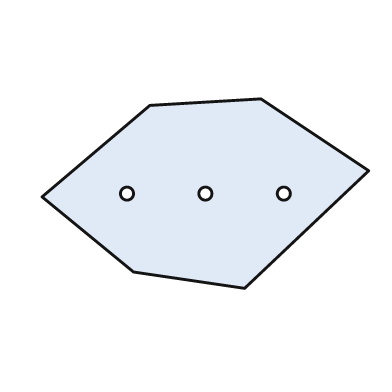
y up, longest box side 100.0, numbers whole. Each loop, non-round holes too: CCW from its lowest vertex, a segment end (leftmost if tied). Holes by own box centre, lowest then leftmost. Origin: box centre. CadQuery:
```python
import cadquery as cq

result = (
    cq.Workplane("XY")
    .moveTo(12.0, -29.0)
    .lineTo(50.0, 7.0)
    .lineTo(17.0, 29.0)
    .lineTo(-17.0, 27.0)
    .lineTo(-50.0, -1.0)
    .lineTo(-22.0, -24.0)
    .close()
    .moveTo(-24.0, 0.0)
    .circle(2.0)
    .moveTo(0.0, 0.0)
    .circle(2.0)
    .moveTo(24.0, 0.0)
    .circle(2.0)
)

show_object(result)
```